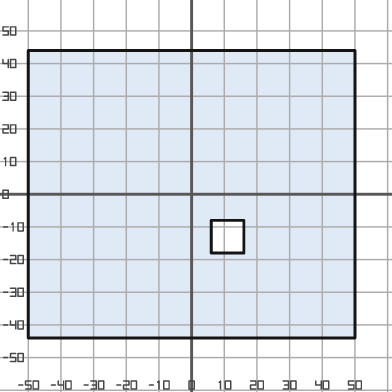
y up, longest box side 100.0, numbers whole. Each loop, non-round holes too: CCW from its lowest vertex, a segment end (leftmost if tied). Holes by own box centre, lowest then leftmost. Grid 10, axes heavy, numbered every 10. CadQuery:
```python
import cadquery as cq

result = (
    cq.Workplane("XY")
    .moveTo(-50.0, -44.0)
    .lineTo(50.0, -44.0)
    .lineTo(50.0, 44.0)
    .lineTo(-50.0, 44.0)
    .close()
    .moveTo(6.0, -18.0)
    .lineTo(16.0, -18.0)
    .lineTo(16.0, -8.0)
    .lineTo(6.0, -8.0)
    .close()
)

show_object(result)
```